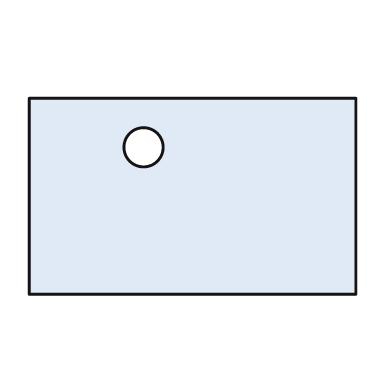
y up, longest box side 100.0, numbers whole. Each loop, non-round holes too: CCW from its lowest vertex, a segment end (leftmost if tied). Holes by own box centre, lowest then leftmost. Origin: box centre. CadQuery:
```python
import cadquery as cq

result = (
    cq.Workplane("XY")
    .moveTo(-50.0, -30.0)
    .lineTo(50.0, -30.0)
    .lineTo(50.0, 30.0)
    .lineTo(-50.0, 30.0)
    .close()
    .moveTo(-15.0, 15.0)
    .circle(6.0)
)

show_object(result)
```